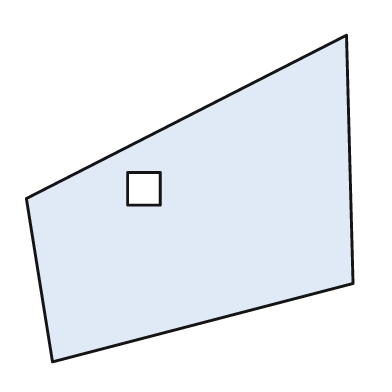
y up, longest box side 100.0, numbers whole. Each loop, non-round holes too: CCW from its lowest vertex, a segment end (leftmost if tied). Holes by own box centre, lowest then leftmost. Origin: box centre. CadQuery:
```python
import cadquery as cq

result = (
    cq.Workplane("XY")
    .moveTo(-42.0, -50.0)
    .lineTo(50.0, -26.0)
    .lineTo(48.0, 50.0)
    .lineTo(-50.0, 0.0)
    .close()
    .moveTo(-19.0, -2.0)
    .lineTo(-9.0, -2.0)
    .lineTo(-9.0, 8.0)
    .lineTo(-19.0, 8.0)
    .close()
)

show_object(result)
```